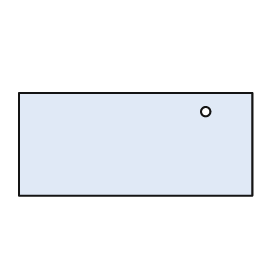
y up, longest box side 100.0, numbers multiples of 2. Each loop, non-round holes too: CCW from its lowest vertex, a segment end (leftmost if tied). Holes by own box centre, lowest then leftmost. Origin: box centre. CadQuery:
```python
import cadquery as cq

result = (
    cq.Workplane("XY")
    .moveTo(-50.0, -22.0)
    .lineTo(50.0, -22.0)
    .lineTo(50.0, 22.0)
    .lineTo(-50.0, 22.0)
    .close()
    .moveTo(30.0, 14.0)
    .circle(2.0)
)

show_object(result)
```